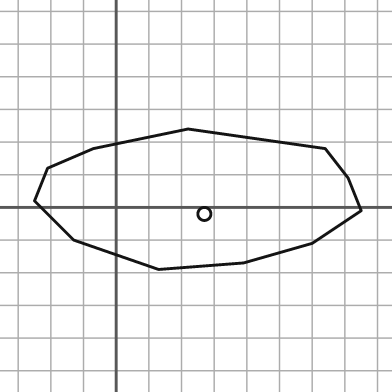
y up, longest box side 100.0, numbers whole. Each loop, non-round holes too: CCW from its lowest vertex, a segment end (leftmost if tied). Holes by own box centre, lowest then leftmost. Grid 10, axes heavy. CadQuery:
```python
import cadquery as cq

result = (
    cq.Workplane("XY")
    .moveTo(13.0, -19.0)
    .lineTo(39.0, -17.0)
    .lineTo(60.0, -11.0)
    .lineTo(75.0, -1.0)
    .lineTo(71.0, 9.0)
    .lineTo(64.0, 18.0)
    .lineTo(22.0, 24.0)
    .lineTo(-7.0, 18.0)
    .lineTo(-21.0, 12.0)
    .lineTo(-25.0, 2.0)
    .lineTo(-13.0, -10.0)
    .close()
    .moveTo(27.0, -2.0)
    .circle(2.0)
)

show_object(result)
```